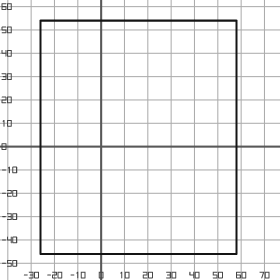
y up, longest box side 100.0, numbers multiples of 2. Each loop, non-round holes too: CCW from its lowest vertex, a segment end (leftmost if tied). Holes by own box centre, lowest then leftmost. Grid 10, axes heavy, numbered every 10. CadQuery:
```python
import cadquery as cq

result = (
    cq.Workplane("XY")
    .moveTo(-26.0, -46.0)
    .lineTo(58.0, -46.0)
    .lineTo(58.0, 54.0)
    .lineTo(-26.0, 54.0)
    .close()
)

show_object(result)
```